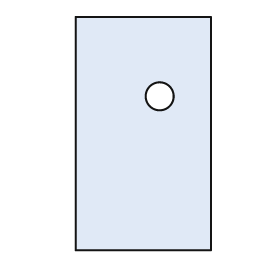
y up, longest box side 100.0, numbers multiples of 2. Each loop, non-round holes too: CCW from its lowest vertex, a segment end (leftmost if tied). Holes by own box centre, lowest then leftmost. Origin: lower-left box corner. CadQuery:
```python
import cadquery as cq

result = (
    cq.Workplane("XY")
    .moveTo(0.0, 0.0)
    .lineTo(58.0, 0.0)
    .lineTo(58.0, 100.0)
    .lineTo(0.0, 100.0)
    .close()
    .moveTo(36.0, 66.0)
    .circle(6.0)
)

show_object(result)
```